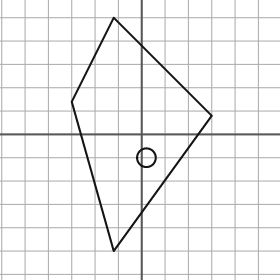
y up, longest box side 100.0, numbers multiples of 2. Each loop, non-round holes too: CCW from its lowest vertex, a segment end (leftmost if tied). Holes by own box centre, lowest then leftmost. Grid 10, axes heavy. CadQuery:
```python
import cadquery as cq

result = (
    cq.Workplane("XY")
    .moveTo(-12.0, -50.0)
    .lineTo(30.0, 8.0)
    .lineTo(-12.0, 50.0)
    .lineTo(-30.0, 14.0)
    .close()
    .moveTo(2.0, -10.0)
    .circle(4.0)
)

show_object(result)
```